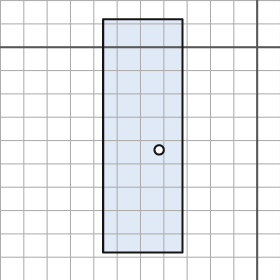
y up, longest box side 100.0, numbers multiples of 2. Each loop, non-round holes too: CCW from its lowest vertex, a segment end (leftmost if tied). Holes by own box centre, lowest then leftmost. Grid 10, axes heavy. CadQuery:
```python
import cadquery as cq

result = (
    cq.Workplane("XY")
    .moveTo(-66.0, -88.0)
    .lineTo(-32.0, -88.0)
    .lineTo(-32.0, 12.0)
    .lineTo(-66.0, 12.0)
    .close()
    .moveTo(-42.0, -44.0)
    .circle(2.0)
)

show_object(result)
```